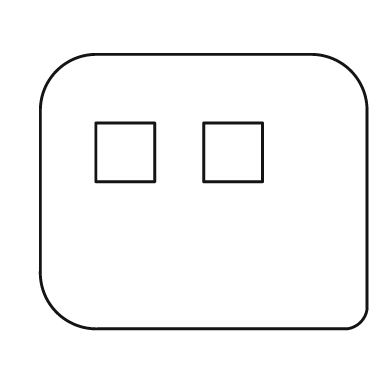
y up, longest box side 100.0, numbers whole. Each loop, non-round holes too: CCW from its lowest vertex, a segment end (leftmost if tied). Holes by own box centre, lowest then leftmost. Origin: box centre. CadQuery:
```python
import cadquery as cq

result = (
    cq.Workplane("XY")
    .moveTo(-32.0, -42.0)
    .lineTo(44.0, -42.0)
    .threePointArc((48.0, -40.0), (50.0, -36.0))
    .lineTo(50.0, 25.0)
    .threePointArc((45.0, 37.0), (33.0, 42.0))
    .lineTo(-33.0, 42.0)
    .threePointArc((-45.0, 37.0), (-50.0, 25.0))
    .lineTo(-50.0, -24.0)
    .threePointArc((-45.0, -37.0), (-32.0, -42.0))
    .close()
    .moveTo(-33.0, 3.0)
    .lineTo(-15.0, 3.0)
    .lineTo(-15.0, 21.0)
    .lineTo(-33.0, 21.0)
    .close()
    .moveTo(0.0, 3.0)
    .lineTo(18.0, 3.0)
    .lineTo(18.0, 21.0)
    .lineTo(0.0, 21.0)
    .close()
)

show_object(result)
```